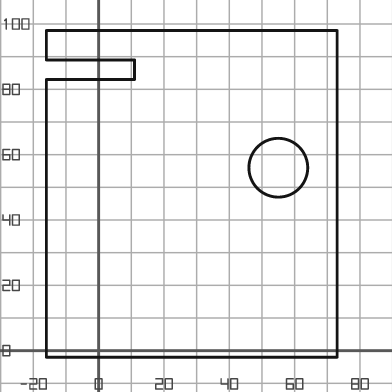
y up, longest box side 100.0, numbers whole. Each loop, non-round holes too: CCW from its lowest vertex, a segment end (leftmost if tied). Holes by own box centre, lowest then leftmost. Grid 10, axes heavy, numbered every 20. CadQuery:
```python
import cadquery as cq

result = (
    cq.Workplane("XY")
    .moveTo(-16.0, -2.0)
    .lineTo(73.0, -2.0)
    .lineTo(73.0, 98.0)
    .lineTo(-16.0, 98.0)
    .lineTo(-16.0, 89.0)
    .lineTo(11.0, 89.0)
    .lineTo(11.0, 83.0)
    .lineTo(-16.0, 83.0)
    .close()
    .moveTo(55.0, 56.0)
    .circle(9.0)
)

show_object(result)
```